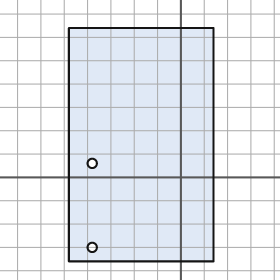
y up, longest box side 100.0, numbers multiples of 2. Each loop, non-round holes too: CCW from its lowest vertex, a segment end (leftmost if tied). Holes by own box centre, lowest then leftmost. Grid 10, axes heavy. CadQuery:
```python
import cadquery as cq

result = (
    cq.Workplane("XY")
    .moveTo(-48.0, -36.0)
    .lineTo(14.0, -36.0)
    .lineTo(14.0, 64.0)
    .lineTo(-48.0, 64.0)
    .close()
    .moveTo(-38.0, -30.0)
    .circle(2.0)
    .moveTo(-38.0, 6.0)
    .circle(2.0)
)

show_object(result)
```